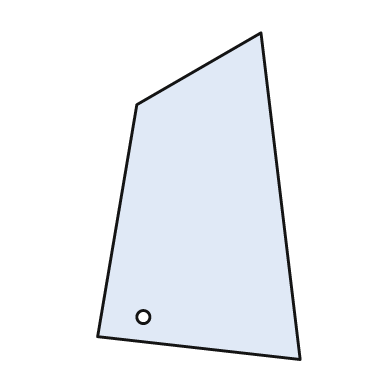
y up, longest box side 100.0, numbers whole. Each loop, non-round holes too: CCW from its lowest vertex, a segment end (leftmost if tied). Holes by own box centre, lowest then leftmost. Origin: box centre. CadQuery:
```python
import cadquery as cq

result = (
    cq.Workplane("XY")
    .moveTo(31.0, -50.0)
    .lineTo(19.0, 50.0)
    .lineTo(-19.0, 28.0)
    .lineTo(-31.0, -43.0)
    .close()
    .moveTo(-17.0, -37.0)
    .circle(2.0)
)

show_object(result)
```